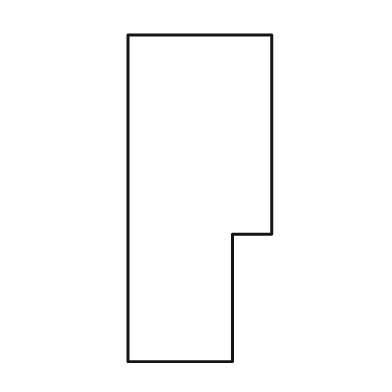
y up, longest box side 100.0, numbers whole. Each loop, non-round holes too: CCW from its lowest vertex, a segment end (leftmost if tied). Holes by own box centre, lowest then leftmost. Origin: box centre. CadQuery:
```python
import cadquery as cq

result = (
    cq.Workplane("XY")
    .moveTo(-22.0, -50.0)
    .lineTo(10.0, -50.0)
    .lineTo(10.0, -11.0)
    .lineTo(22.0, -11.0)
    .lineTo(22.0, 50.0)
    .lineTo(-22.0, 50.0)
    .close()
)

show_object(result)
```